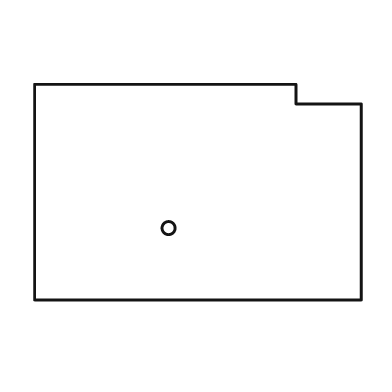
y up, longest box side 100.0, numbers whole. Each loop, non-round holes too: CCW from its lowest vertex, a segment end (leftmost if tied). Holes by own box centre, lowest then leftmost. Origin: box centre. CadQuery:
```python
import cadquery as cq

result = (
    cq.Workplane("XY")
    .moveTo(-50.0, -33.0)
    .lineTo(50.0, -33.0)
    .lineTo(50.0, 27.0)
    .lineTo(30.0, 27.0)
    .lineTo(30.0, 33.0)
    .lineTo(-50.0, 33.0)
    .close()
    .moveTo(-9.0, -11.0)
    .circle(2.0)
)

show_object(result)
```